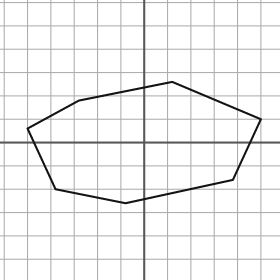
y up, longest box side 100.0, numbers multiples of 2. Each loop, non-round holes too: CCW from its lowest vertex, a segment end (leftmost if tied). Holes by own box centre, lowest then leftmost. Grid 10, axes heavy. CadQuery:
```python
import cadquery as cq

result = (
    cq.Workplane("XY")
    .moveTo(-8.0, -26.0)
    .lineTo(38.0, -16.0)
    .lineTo(50.0, 10.0)
    .lineTo(12.0, 26.0)
    .lineTo(-28.0, 18.0)
    .lineTo(-50.0, 6.0)
    .lineTo(-38.0, -20.0)
    .close()
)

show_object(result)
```